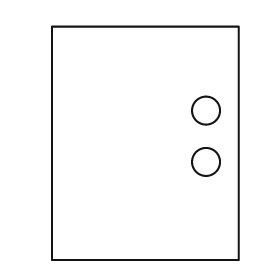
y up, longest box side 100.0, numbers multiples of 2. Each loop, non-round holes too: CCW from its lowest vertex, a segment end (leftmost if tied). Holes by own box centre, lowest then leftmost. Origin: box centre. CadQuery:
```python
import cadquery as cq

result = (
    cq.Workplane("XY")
    .moveTo(-40.0, -50.0)
    .lineTo(40.0, -50.0)
    .lineTo(40.0, 50.0)
    .lineTo(-40.0, 50.0)
    .close()
    .moveTo(26.0, -8.0)
    .circle(6.0)
    .moveTo(26.0, 14.0)
    .circle(6.0)
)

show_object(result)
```